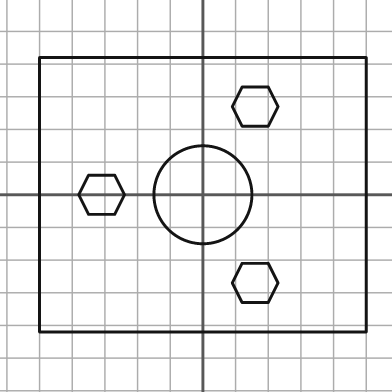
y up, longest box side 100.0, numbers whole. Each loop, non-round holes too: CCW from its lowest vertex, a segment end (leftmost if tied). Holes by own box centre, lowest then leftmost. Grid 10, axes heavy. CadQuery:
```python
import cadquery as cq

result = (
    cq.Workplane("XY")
    .moveTo(-50.0, -42.0)
    .lineTo(50.0, -42.0)
    .lineTo(50.0, 42.0)
    .lineTo(-50.0, 42.0)
    .close()
    .moveTo(12.0, -33.0)
    .lineTo(20.0, -33.0)
    .lineTo(23.0, -27.0)
    .lineTo(20.0, -21.0)
    .lineTo(12.0, -21.0)
    .lineTo(9.0, -27.0)
    .close()
    .moveTo(-35.0, -6.0)
    .lineTo(-27.0, -6.0)
    .lineTo(-24.0, 0.0)
    .lineTo(-27.0, 6.0)
    .lineTo(-35.0, 6.0)
    .lineTo(-38.0, 0.0)
    .close()
    .moveTo(0.0, 0.0)
    .circle(15.0)
    .moveTo(12.0, 21.0)
    .lineTo(20.0, 21.0)
    .lineTo(23.0, 27.0)
    .lineTo(20.0, 33.0)
    .lineTo(12.0, 33.0)
    .lineTo(9.0, 27.0)
    .close()
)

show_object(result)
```